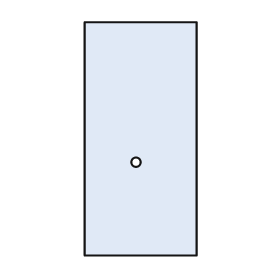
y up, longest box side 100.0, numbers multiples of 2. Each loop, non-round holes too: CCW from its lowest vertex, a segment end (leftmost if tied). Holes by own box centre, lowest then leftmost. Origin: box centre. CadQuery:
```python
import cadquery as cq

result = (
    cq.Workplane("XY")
    .moveTo(-24.0, -50.0)
    .lineTo(24.0, -50.0)
    .lineTo(24.0, 50.0)
    .lineTo(-24.0, 50.0)
    .close()
    .moveTo(-2.0, -10.0)
    .circle(2.0)
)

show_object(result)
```